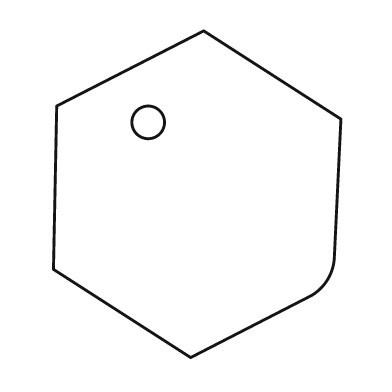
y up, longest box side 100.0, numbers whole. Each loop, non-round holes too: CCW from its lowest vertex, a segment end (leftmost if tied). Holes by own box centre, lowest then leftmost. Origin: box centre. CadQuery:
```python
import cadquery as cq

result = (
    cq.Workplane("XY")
    .moveTo(-2.0, -50.0)
    .lineTo(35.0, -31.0)
    .threePointArc((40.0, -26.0), (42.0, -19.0))
    .lineTo(44.0, 23.0)
    .lineTo(2.0, 50.0)
    .lineTo(-43.0, 27.0)
    .lineTo(-44.0, -23.0)
    .close()
    .moveTo(-15.0, 22.0)
    .circle(5.0)
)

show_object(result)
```